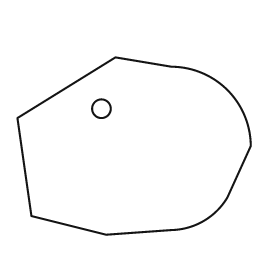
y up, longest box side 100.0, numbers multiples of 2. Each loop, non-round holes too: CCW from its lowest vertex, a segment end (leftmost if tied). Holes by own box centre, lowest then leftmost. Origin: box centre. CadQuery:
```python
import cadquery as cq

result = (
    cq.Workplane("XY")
    .moveTo(-12.0, -38.0)
    .lineTo(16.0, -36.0)
    .threePointArc((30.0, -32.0), (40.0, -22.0))
    .lineTo(50.0, 0.0)
    .threePointArc((40.0, 24.0), (16.0, 34.0))
    .lineTo(-8.0, 38.0)
    .lineTo(-50.0, 12.0)
    .lineTo(-44.0, -30.0)
    .close()
    .moveTo(-14.0, 16.0)
    .circle(4.0)
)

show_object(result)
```